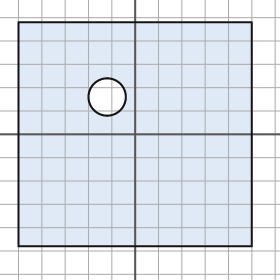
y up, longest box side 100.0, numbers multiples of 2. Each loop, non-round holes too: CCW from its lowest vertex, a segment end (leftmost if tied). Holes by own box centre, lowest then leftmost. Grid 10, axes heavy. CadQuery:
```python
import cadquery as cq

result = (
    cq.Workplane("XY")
    .moveTo(-50.0, -48.0)
    .lineTo(50.0, -48.0)
    .lineTo(50.0, 48.0)
    .lineTo(-50.0, 48.0)
    .close()
    .moveTo(-12.0, 16.0)
    .circle(8.0)
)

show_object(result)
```